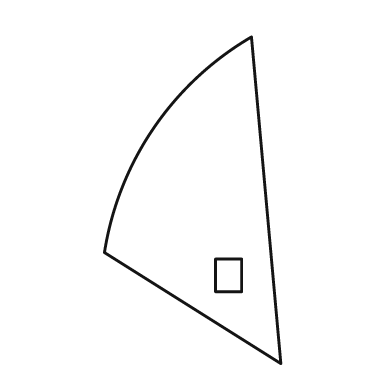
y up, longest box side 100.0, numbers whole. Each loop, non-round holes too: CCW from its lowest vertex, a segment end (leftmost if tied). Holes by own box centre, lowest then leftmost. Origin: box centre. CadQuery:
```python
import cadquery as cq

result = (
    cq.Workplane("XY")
    .moveTo(27.0, -50.0)
    .lineTo(18.0, 50.0)
    .threePointArc((-12.0, 22.0), (-27.0, -16.0))
    .close()
    .moveTo(7.0, -28.0)
    .lineTo(15.0, -28.0)
    .lineTo(15.0, -18.0)
    .lineTo(7.0, -18.0)
    .close()
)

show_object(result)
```